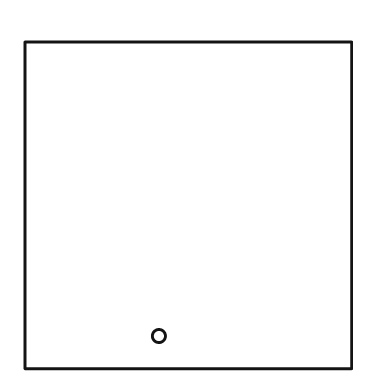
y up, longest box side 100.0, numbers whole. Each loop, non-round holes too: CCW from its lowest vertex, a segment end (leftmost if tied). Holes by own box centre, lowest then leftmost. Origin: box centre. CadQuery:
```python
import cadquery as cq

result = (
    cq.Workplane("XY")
    .moveTo(-50.0, -50.0)
    .lineTo(50.0, -50.0)
    .lineTo(50.0, 50.0)
    .lineTo(-50.0, 50.0)
    .close()
    .moveTo(-9.0, -40.0)
    .circle(2.0)
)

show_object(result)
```